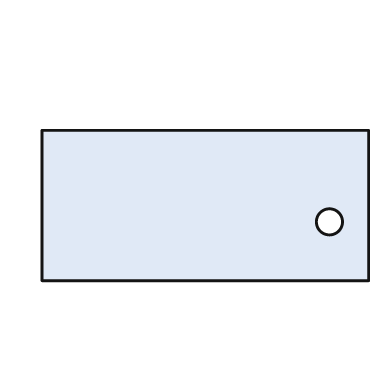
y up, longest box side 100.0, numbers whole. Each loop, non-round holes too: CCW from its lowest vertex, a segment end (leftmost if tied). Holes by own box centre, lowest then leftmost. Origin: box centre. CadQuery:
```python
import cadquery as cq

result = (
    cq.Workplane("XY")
    .moveTo(-50.0, -23.0)
    .lineTo(50.0, -23.0)
    .lineTo(50.0, 23.0)
    .lineTo(-50.0, 23.0)
    .close()
    .moveTo(38.0, -5.0)
    .circle(4.0)
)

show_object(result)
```